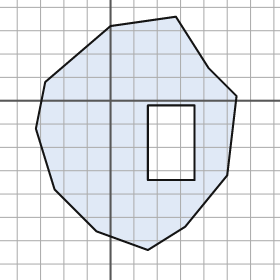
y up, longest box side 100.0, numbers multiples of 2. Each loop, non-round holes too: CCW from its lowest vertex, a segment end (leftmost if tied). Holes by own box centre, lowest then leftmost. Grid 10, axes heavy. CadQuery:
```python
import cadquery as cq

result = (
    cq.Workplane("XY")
    .moveTo(16.0, -64.0)
    .lineTo(32.0, -54.0)
    .lineTo(50.0, -32.0)
    .lineTo(54.0, 2.0)
    .lineTo(42.0, 14.0)
    .lineTo(28.0, 36.0)
    .lineTo(0.0, 32.0)
    .lineTo(-28.0, 8.0)
    .lineTo(-32.0, -12.0)
    .lineTo(-24.0, -38.0)
    .lineTo(-6.0, -56.0)
    .close()
    .moveTo(16.0, -34.0)
    .lineTo(36.0, -34.0)
    .lineTo(36.0, -2.0)
    .lineTo(16.0, -2.0)
    .close()
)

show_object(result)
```